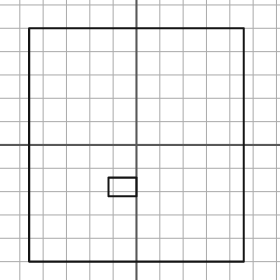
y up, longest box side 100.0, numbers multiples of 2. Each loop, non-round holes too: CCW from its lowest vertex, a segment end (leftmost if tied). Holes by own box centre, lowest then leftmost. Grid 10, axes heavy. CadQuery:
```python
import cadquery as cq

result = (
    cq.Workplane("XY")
    .moveTo(-46.0, -50.0)
    .lineTo(46.0, -50.0)
    .lineTo(46.0, 50.0)
    .lineTo(-46.0, 50.0)
    .close()
    .moveTo(-12.0, -22.0)
    .lineTo(0.0, -22.0)
    .lineTo(0.0, -14.0)
    .lineTo(-12.0, -14.0)
    .close()
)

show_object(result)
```